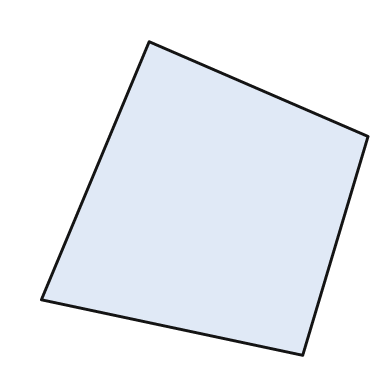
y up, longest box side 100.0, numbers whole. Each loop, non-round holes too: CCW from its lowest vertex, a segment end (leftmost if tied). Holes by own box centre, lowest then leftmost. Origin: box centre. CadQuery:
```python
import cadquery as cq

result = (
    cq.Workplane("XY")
    .moveTo(30.0, -48.0)
    .lineTo(50.0, 19.0)
    .lineTo(-17.0, 48.0)
    .lineTo(-50.0, -31.0)
    .close()
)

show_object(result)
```